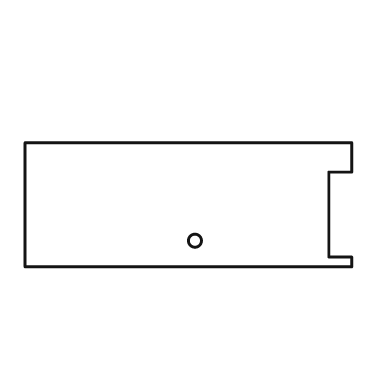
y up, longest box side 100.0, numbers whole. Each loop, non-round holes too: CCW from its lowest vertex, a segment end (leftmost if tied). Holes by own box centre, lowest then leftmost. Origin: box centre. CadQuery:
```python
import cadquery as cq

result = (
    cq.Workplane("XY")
    .moveTo(-50.0, -19.0)
    .lineTo(50.0, -19.0)
    .lineTo(50.0, -16.0)
    .lineTo(43.0, -16.0)
    .lineTo(43.0, 10.0)
    .lineTo(50.0, 10.0)
    .lineTo(50.0, 19.0)
    .lineTo(-50.0, 19.0)
    .close()
    .moveTo(2.0, -11.0)
    .circle(2.0)
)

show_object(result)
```